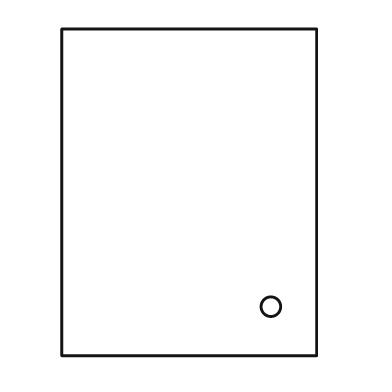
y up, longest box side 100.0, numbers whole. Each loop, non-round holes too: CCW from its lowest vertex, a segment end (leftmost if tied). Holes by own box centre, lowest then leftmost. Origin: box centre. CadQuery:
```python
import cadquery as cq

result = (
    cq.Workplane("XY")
    .moveTo(-39.0, -50.0)
    .lineTo(39.0, -50.0)
    .lineTo(39.0, 50.0)
    .lineTo(-39.0, 50.0)
    .close()
    .moveTo(25.0, -35.0)
    .circle(3.0)
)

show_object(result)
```